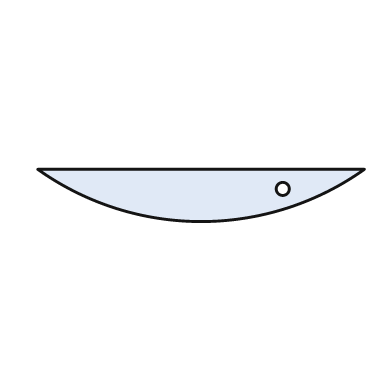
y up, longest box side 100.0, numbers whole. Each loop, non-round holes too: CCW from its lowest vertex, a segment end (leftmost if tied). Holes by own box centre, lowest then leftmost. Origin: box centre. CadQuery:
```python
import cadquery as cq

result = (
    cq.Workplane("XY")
    .moveTo(-50.0, 8.0)
    .threePointArc((0.0, -8.0), (50.0, 8.0))
    .close()
    .moveTo(25.0, 2.0)
    .circle(2.0)
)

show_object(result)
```